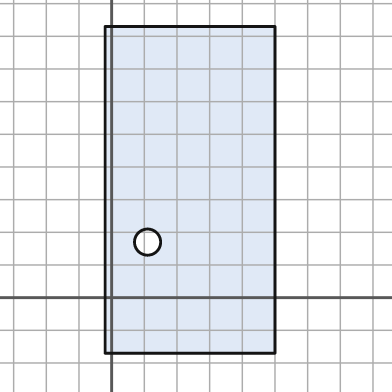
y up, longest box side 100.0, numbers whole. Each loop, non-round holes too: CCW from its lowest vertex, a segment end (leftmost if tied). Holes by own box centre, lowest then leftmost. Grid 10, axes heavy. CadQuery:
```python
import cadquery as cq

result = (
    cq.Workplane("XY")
    .moveTo(-2.0, -17.0)
    .lineTo(50.0, -17.0)
    .lineTo(50.0, 83.0)
    .lineTo(-2.0, 83.0)
    .close()
    .moveTo(11.0, 17.0)
    .circle(4.0)
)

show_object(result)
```